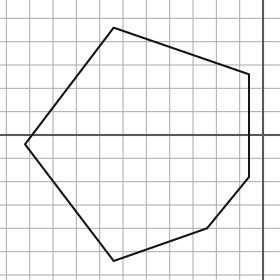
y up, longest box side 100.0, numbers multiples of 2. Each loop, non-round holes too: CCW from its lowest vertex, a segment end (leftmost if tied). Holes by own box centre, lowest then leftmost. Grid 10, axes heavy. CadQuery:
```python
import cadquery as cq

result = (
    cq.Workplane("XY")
    .moveTo(-64.0, -54.0)
    .lineTo(-24.0, -40.0)
    .lineTo(-6.0, -18.0)
    .lineTo(-6.0, 26.0)
    .lineTo(-64.0, 46.0)
    .lineTo(-102.0, -4.0)
    .close()
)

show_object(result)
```